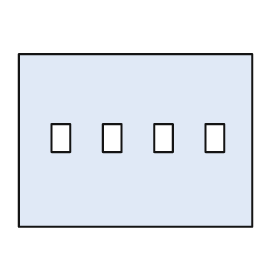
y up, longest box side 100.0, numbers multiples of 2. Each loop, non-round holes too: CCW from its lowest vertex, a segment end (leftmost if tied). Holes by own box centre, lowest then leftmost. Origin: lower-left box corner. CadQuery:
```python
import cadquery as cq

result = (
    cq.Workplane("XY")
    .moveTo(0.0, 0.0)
    .lineTo(100.0, 0.0)
    .lineTo(100.0, 74.0)
    .lineTo(0.0, 74.0)
    .close()
    .moveTo(14.0, 32.0)
    .lineTo(22.0, 32.0)
    .lineTo(22.0, 44.0)
    .lineTo(14.0, 44.0)
    .close()
    .moveTo(36.0, 32.0)
    .lineTo(44.0, 32.0)
    .lineTo(44.0, 44.0)
    .lineTo(36.0, 44.0)
    .close()
    .moveTo(58.0, 32.0)
    .lineTo(66.0, 32.0)
    .lineTo(66.0, 44.0)
    .lineTo(58.0, 44.0)
    .close()
    .moveTo(80.0, 32.0)
    .lineTo(88.0, 32.0)
    .lineTo(88.0, 44.0)
    .lineTo(80.0, 44.0)
    .close()
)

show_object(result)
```